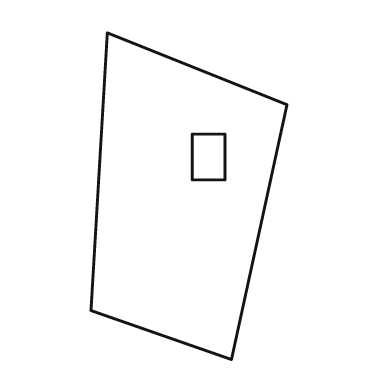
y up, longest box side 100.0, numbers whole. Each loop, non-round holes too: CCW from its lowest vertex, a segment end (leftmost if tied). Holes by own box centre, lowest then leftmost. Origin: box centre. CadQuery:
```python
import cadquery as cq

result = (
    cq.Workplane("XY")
    .moveTo(13.0, -50.0)
    .lineTo(30.0, 28.0)
    .lineTo(-25.0, 50.0)
    .lineTo(-30.0, -35.0)
    .close()
    .moveTo(1.0, 5.0)
    .lineTo(11.0, 5.0)
    .lineTo(11.0, 19.0)
    .lineTo(1.0, 19.0)
    .close()
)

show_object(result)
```